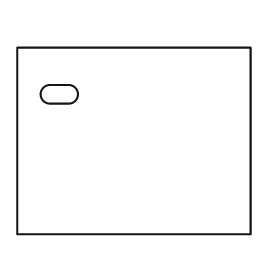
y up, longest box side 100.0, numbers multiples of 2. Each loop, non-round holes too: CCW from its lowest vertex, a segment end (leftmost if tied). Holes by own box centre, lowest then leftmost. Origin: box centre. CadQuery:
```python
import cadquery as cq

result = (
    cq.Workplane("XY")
    .moveTo(-50.0, -40.0)
    .lineTo(50.0, -40.0)
    .lineTo(50.0, 40.0)
    .lineTo(-50.0, 40.0)
    .close()
    .moveTo(-36.0, 16.0)
    .lineTo(-28.0, 16.0)
    .threePointArc((-24.0, 20.0), (-28.0, 24.0))
    .lineTo(-36.0, 24.0)
    .threePointArc((-40.0, 20.0), (-36.0, 16.0))
    .close()
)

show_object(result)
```